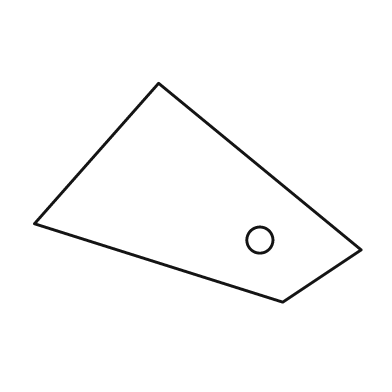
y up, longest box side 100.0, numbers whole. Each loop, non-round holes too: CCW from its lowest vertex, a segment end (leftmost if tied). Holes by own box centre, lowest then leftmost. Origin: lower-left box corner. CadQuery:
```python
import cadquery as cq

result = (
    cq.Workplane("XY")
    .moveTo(76.0, 0.0)
    .lineTo(100.0, 16.0)
    .lineTo(38.0, 67.0)
    .lineTo(0.0, 24.0)
    .close()
    .moveTo(69.0, 19.0)
    .circle(4.0)
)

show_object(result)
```